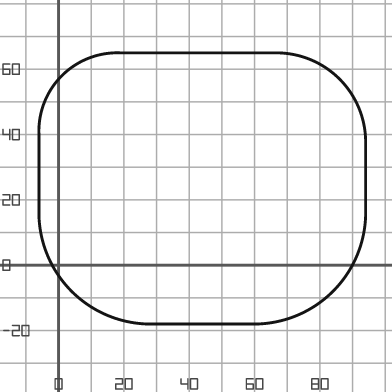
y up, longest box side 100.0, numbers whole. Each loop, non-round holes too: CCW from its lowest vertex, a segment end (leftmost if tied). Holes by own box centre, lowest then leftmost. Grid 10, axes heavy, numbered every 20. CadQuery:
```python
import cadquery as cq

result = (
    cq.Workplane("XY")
    .moveTo(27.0, -18.0)
    .lineTo(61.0, -18.0)
    .threePointArc((84.0, -8.0), (94.0, 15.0))
    .lineTo(94.0, 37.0)
    .threePointArc((86.0, 57.0), (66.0, 65.0))
    .lineTo(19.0, 65.0)
    .threePointArc((1.0, 58.0), (-6.0, 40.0))
    .lineTo(-6.0, 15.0)
    .threePointArc((4.0, -8.0), (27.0, -18.0))
    .close()
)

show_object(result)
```